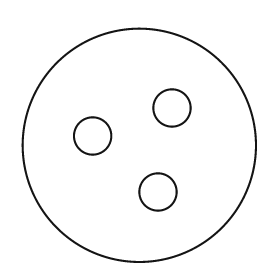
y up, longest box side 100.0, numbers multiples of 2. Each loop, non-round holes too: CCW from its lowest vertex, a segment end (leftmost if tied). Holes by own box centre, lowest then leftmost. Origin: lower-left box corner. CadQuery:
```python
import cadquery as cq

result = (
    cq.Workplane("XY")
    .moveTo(50.0, 50.0)
    .circle(50.0)
    .moveTo(58.0, 30.0)
    .circle(8.0)
    .moveTo(30.0, 54.0)
    .circle(8.0)
    .moveTo(64.0, 66.0)
    .circle(8.0)
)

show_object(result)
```